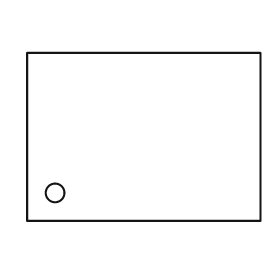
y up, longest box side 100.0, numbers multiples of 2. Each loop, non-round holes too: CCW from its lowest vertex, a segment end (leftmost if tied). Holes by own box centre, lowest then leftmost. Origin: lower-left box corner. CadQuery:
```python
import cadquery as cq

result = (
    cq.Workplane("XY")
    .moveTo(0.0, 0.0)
    .lineTo(100.0, 0.0)
    .lineTo(100.0, 72.0)
    .lineTo(0.0, 72.0)
    .close()
    .moveTo(12.0, 12.0)
    .circle(4.0)
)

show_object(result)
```